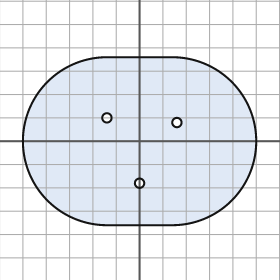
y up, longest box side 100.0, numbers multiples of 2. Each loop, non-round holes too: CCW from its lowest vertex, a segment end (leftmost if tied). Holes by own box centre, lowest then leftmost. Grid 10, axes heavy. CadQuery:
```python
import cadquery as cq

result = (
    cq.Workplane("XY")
    .moveTo(-14.0, -36.0)
    .lineTo(14.0, -36.0)
    .threePointArc((50.0, 0.0), (14.0, 36.0))
    .lineTo(-14.0, 36.0)
    .threePointArc((-50.0, 0.0), (-14.0, -36.0))
    .close()
    .moveTo(0.0, -18.0)
    .circle(2.0)
    .moveTo(16.0, 8.0)
    .circle(2.0)
    .moveTo(-14.0, 10.0)
    .circle(2.0)
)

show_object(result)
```